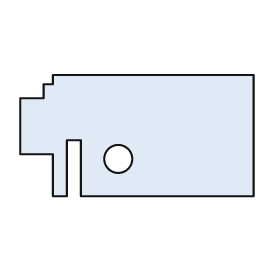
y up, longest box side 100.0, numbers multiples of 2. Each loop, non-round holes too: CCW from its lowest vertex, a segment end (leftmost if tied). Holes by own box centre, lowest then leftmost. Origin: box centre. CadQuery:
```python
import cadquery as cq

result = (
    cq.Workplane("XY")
    .moveTo(-36.0, -26.0)
    .lineTo(-30.0, -26.0)
    .lineTo(-30.0, -2.0)
    .lineTo(-24.0, -2.0)
    .lineTo(-24.0, -26.0)
    .lineTo(50.0, -26.0)
    .lineTo(50.0, 26.0)
    .lineTo(-36.0, 26.0)
    .lineTo(-36.0, 22.0)
    .lineTo(-40.0, 22.0)
    .lineTo(-40.0, 16.0)
    .lineTo(-50.0, 16.0)
    .lineTo(-50.0, -8.0)
    .lineTo(-36.0, -8.0)
    .close()
    .moveTo(-8.0, -10.0)
    .circle(6.0)
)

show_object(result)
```